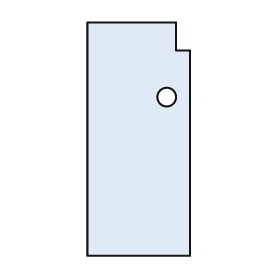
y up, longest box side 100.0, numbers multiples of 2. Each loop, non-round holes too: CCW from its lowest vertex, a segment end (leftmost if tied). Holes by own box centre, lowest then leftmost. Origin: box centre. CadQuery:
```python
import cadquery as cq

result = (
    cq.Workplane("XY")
    .moveTo(-22.0, -50.0)
    .lineTo(22.0, -50.0)
    .lineTo(22.0, 38.0)
    .lineTo(16.0, 38.0)
    .lineTo(16.0, 50.0)
    .lineTo(-22.0, 50.0)
    .close()
    .moveTo(12.0, 18.0)
    .circle(4.0)
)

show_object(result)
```